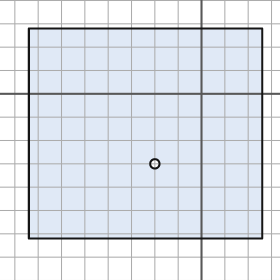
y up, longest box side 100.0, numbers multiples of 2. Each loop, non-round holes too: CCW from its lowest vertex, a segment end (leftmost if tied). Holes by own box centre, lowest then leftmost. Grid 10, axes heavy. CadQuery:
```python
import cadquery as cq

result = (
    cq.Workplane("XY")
    .moveTo(-74.0, -62.0)
    .lineTo(26.0, -62.0)
    .lineTo(26.0, 28.0)
    .lineTo(-74.0, 28.0)
    .close()
    .moveTo(-20.0, -30.0)
    .circle(2.0)
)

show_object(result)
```